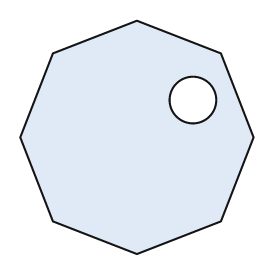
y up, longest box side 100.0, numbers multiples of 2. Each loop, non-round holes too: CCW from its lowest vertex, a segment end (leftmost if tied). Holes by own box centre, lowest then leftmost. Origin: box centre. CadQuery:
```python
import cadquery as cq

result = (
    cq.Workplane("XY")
    .moveTo(0.0, -50.0)
    .lineTo(36.0, -36.0)
    .lineTo(50.0, 0.0)
    .lineTo(36.0, 36.0)
    .lineTo(0.0, 50.0)
    .lineTo(-36.0, 36.0)
    .lineTo(-50.0, 0.0)
    .lineTo(-36.0, -36.0)
    .close()
    .moveTo(24.0, 16.0)
    .circle(10.0)
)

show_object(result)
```